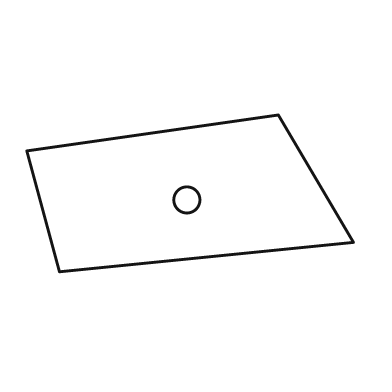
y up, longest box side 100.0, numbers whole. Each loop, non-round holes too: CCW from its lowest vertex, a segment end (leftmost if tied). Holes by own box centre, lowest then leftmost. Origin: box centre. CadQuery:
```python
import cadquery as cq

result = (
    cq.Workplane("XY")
    .moveTo(-40.0, -24.0)
    .lineTo(50.0, -15.0)
    .lineTo(27.0, 24.0)
    .lineTo(-50.0, 13.0)
    .close()
    .moveTo(-1.0, -2.0)
    .circle(4.0)
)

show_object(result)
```